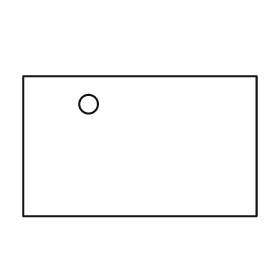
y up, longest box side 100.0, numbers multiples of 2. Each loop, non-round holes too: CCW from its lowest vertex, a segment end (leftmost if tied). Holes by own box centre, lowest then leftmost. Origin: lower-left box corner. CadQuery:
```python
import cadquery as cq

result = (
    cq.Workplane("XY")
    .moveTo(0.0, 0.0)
    .lineTo(100.0, 0.0)
    .lineTo(100.0, 60.0)
    .lineTo(0.0, 60.0)
    .close()
    .moveTo(28.0, 48.0)
    .circle(4.0)
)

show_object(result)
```